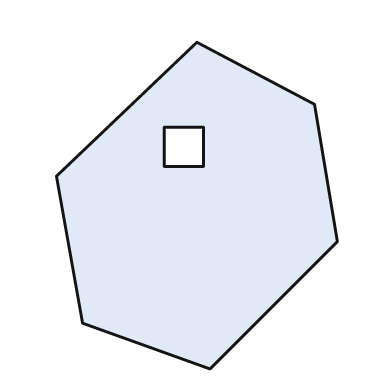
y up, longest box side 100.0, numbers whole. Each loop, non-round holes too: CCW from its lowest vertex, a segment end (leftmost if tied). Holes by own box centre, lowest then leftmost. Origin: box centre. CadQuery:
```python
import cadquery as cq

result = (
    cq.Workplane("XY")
    .moveTo(4.0, -50.0)
    .lineTo(43.0, -11.0)
    .lineTo(36.0, 31.0)
    .lineTo(0.0, 50.0)
    .lineTo(-43.0, 9.0)
    .lineTo(-35.0, -36.0)
    .close()
    .moveTo(-10.0, 12.0)
    .lineTo(2.0, 12.0)
    .lineTo(2.0, 24.0)
    .lineTo(-10.0, 24.0)
    .close()
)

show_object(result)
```